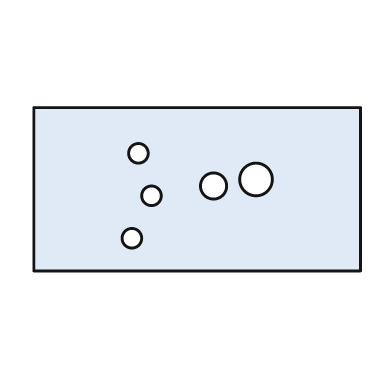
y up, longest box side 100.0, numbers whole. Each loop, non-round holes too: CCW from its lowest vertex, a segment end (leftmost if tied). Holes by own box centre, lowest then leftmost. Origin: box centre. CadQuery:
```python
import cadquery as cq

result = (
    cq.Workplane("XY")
    .moveTo(-50.0, -25.0)
    .lineTo(50.0, -25.0)
    .lineTo(50.0, 25.0)
    .lineTo(-50.0, 25.0)
    .close()
    .moveTo(-20.0, -15.0)
    .circle(3.0)
    .moveTo(-14.0, -2.0)
    .circle(3.0)
    .moveTo(5.0, 1.0)
    .circle(4.0)
    .moveTo(18.0, 3.0)
    .circle(5.0)
    .moveTo(-18.0, 11.0)
    .circle(3.0)
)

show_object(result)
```